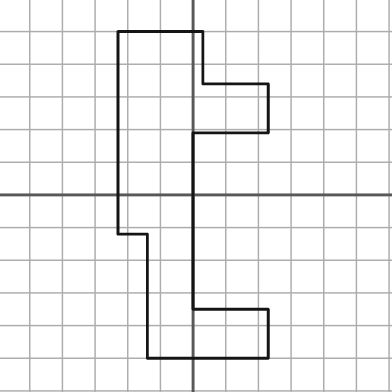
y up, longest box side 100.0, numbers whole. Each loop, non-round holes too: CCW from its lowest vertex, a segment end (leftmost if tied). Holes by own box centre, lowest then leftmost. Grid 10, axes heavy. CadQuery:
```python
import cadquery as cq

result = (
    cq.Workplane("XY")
    .moveTo(-14.0, -50.0)
    .lineTo(23.0, -50.0)
    .lineTo(23.0, -35.0)
    .lineTo(0.0, -35.0)
    .lineTo(0.0, 19.0)
    .lineTo(23.0, 19.0)
    .lineTo(23.0, 34.0)
    .lineTo(3.0, 34.0)
    .lineTo(3.0, 50.0)
    .lineTo(-23.0, 50.0)
    .lineTo(-23.0, -12.0)
    .lineTo(-14.0, -12.0)
    .close()
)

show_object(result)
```